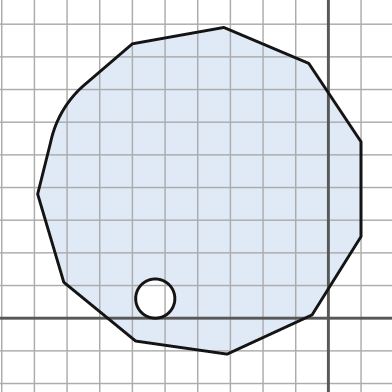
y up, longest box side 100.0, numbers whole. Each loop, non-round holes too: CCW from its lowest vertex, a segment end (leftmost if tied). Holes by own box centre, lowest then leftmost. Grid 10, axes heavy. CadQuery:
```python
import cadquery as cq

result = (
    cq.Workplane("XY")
    .moveTo(-31.0, -11.0)
    .lineTo(-5.0, 1.0)
    .lineTo(10.0, 25.0)
    .lineTo(10.0, 54.0)
    .lineTo(-6.0, 78.0)
    .lineTo(-32.0, 89.0)
    .lineTo(-60.0, 84.0)
    .lineTo(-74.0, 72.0)
    .threePointArc((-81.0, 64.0), (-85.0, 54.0))
    .lineTo(-89.0, 38.0)
    .lineTo(-81.0, 11.0)
    .lineTo(-59.0, -7.0)
    .close()
    .moveTo(-53.0, 6.0)
    .circle(6.0)
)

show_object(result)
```